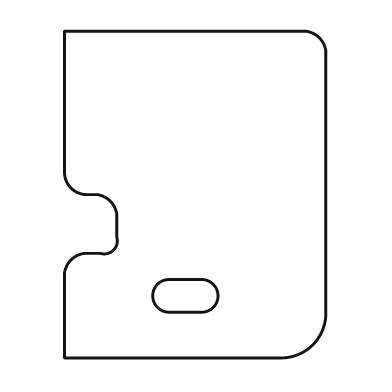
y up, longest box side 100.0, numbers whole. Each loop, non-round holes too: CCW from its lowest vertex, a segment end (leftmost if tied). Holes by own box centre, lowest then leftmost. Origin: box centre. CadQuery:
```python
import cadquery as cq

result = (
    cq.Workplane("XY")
    .moveTo(-40.0, -50.0)
    .lineTo(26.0, -50.0)
    .threePointArc((36.0, -46.0), (40.0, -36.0))
    .lineTo(40.0, 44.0)
    .threePointArc((38.0, 48.0), (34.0, 50.0))
    .lineTo(-40.0, 50.0)
    .lineTo(-40.0, 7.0)
    .threePointArc((-38.0, 2.0), (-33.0, 0.0))
    .lineTo(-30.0, 0.0)
    .threePointArc((-26.0, -2.0), (-24.0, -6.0))
    .lineTo(-24.0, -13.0)
    .threePointArc((-25.0, -17.0), (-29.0, -18.0))
    .lineTo(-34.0, -18.0)
    .threePointArc((-38.0, -20.0), (-40.0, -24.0))
    .close()
    .moveTo(-8.0, -36.0)
    .lineTo(2.0, -36.0)
    .threePointArc((7.0, -31.0), (2.0, -26.0))
    .lineTo(-8.0, -26.0)
    .threePointArc((-13.0, -31.0), (-8.0, -36.0))
    .close()
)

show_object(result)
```